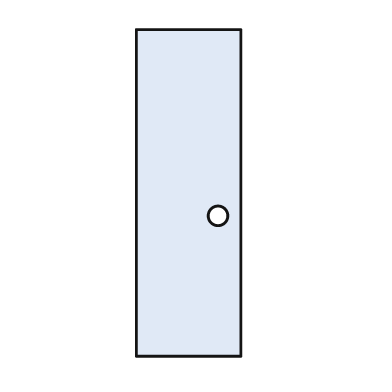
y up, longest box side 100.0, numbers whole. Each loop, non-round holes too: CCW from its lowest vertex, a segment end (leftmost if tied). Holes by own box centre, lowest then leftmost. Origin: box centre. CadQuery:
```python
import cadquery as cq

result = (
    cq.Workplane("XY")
    .moveTo(-16.0, -50.0)
    .lineTo(16.0, -50.0)
    .lineTo(16.0, 50.0)
    .lineTo(-16.0, 50.0)
    .close()
    .moveTo(9.0, -7.0)
    .circle(3.0)
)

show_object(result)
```